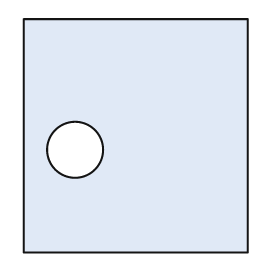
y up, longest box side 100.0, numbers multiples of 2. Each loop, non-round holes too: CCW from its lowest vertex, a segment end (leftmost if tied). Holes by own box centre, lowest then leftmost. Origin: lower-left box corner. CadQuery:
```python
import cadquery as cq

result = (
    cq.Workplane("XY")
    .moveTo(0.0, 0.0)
    .lineTo(96.0, 0.0)
    .lineTo(96.0, 100.0)
    .lineTo(0.0, 100.0)
    .close()
    .moveTo(22.0, 44.0)
    .circle(12.0)
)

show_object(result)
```